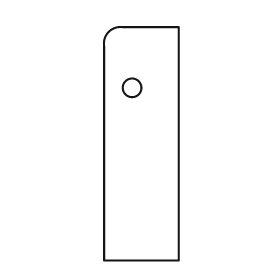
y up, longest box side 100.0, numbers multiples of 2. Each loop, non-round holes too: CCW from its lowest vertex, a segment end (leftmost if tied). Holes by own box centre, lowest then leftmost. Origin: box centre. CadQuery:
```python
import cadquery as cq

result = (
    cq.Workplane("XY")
    .moveTo(-16.0, -50.0)
    .lineTo(16.0, -50.0)
    .lineTo(16.0, 50.0)
    .lineTo(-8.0, 50.0)
    .threePointArc((-14.0, 48.0), (-16.0, 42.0))
    .close()
    .moveTo(-4.0, 24.0)
    .circle(4.0)
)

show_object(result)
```